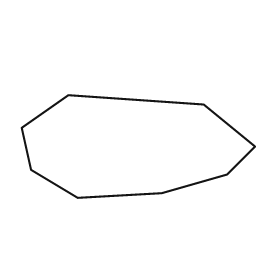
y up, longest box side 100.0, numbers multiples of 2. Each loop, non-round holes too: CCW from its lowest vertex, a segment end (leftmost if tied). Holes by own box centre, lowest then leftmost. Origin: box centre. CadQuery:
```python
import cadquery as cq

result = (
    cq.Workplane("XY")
    .moveTo(-26.0, -22.0)
    .lineTo(10.0, -20.0)
    .lineTo(38.0, -12.0)
    .lineTo(50.0, 0.0)
    .lineTo(28.0, 18.0)
    .lineTo(-30.0, 22.0)
    .lineTo(-50.0, 8.0)
    .lineTo(-46.0, -10.0)
    .close()
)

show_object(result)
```